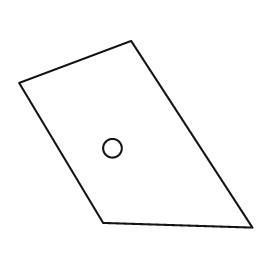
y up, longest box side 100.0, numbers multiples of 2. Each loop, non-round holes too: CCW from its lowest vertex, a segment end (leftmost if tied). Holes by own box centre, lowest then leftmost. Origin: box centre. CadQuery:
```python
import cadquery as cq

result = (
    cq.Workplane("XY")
    .moveTo(50.0, -40.0)
    .lineTo(-2.0, 40.0)
    .lineTo(-50.0, 22.0)
    .lineTo(-14.0, -38.0)
    .close()
    .moveTo(-10.0, -6.0)
    .circle(4.0)
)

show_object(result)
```